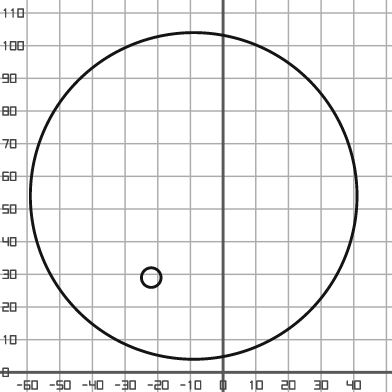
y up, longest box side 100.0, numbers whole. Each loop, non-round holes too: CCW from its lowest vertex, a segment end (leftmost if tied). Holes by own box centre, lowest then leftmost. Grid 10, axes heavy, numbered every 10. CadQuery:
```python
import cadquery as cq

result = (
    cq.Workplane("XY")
    .moveTo(-9.0, 54.0)
    .circle(50.0)
    .moveTo(-22.0, 29.0)
    .circle(3.0)
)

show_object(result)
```